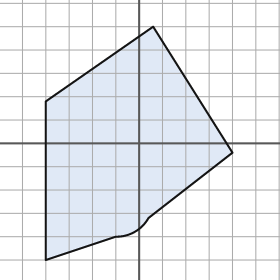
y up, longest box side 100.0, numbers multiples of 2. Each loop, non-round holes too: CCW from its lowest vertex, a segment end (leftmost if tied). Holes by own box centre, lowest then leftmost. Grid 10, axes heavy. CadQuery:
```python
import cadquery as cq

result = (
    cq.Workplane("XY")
    .moveTo(-40.0, -50.0)
    .lineTo(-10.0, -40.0)
    .threePointArc((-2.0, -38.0), (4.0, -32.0))
    .lineTo(40.0, -4.0)
    .lineTo(6.0, 50.0)
    .lineTo(-40.0, 18.0)
    .close()
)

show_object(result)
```